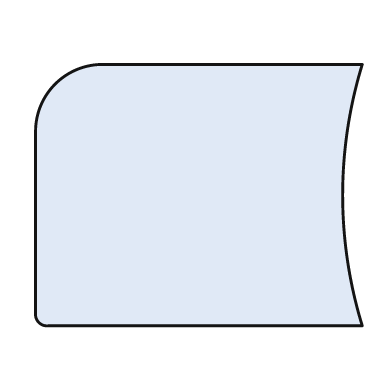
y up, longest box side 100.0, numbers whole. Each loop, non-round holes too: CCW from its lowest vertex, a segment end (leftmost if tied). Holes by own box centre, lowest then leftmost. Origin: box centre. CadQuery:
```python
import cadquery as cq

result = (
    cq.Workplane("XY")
    .moveTo(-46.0, -40.0)
    .lineTo(50.0, -40.0)
    .threePointArc((44.0, 0.0), (50.0, 40.0))
    .lineTo(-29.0, 40.0)
    .threePointArc((-44.0, 34.0), (-50.0, 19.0))
    .lineTo(-50.0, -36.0)
    .threePointArc((-49.0, -39.0), (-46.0, -40.0))
    .close()
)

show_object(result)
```